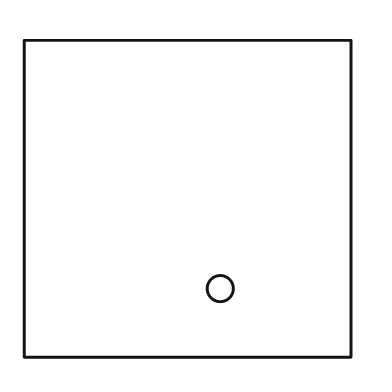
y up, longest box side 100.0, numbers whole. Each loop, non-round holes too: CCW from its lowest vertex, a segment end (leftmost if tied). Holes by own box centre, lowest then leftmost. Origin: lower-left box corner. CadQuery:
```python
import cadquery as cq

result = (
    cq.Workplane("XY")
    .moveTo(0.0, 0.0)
    .lineTo(100.0, 0.0)
    .lineTo(100.0, 97.0)
    .lineTo(0.0, 97.0)
    .close()
    .moveTo(60.0, 21.0)
    .circle(4.0)
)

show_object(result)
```